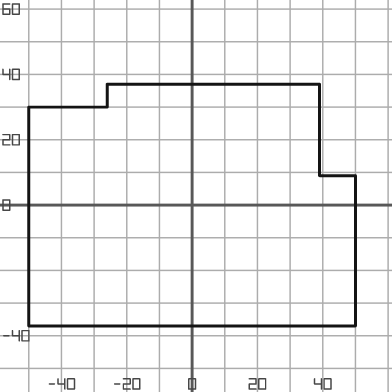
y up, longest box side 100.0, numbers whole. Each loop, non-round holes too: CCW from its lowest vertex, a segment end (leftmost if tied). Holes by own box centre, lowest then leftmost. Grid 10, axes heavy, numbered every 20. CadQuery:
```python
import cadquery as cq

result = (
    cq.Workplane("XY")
    .moveTo(-50.0, -37.0)
    .lineTo(50.0, -37.0)
    .lineTo(50.0, 9.0)
    .lineTo(39.0, 9.0)
    .lineTo(39.0, 37.0)
    .lineTo(-26.0, 37.0)
    .lineTo(-26.0, 30.0)
    .lineTo(-50.0, 30.0)
    .close()
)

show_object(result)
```